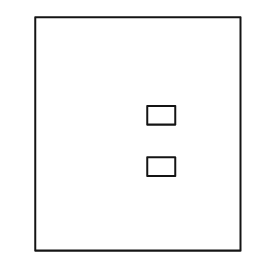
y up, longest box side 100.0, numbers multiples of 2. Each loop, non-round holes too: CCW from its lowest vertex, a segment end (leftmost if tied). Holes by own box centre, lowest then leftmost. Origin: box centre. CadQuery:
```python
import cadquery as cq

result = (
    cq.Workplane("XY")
    .moveTo(-44.0, -50.0)
    .lineTo(44.0, -50.0)
    .lineTo(44.0, 50.0)
    .lineTo(-44.0, 50.0)
    .close()
    .moveTo(4.0, -18.0)
    .lineTo(16.0, -18.0)
    .lineTo(16.0, -10.0)
    .lineTo(4.0, -10.0)
    .close()
    .moveTo(4.0, 4.0)
    .lineTo(16.0, 4.0)
    .lineTo(16.0, 12.0)
    .lineTo(4.0, 12.0)
    .close()
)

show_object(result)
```